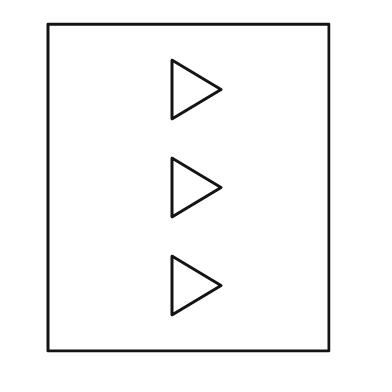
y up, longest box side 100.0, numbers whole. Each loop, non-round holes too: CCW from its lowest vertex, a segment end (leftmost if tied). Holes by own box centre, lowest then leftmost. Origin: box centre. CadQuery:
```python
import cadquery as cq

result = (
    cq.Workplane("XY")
    .moveTo(-43.0, -50.0)
    .lineTo(43.0, -50.0)
    .lineTo(43.0, 50.0)
    .lineTo(-43.0, 50.0)
    .close()
    .moveTo(-5.0, -39.0)
    .lineTo(10.0, -30.0)
    .lineTo(-5.0, -21.0)
    .close()
    .moveTo(-5.0, -9.0)
    .lineTo(10.0, 0.0)
    .lineTo(-5.0, 9.0)
    .close()
    .moveTo(-5.0, 21.0)
    .lineTo(10.0, 30.0)
    .lineTo(-5.0, 39.0)
    .close()
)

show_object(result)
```